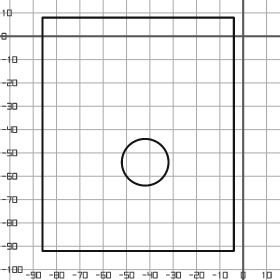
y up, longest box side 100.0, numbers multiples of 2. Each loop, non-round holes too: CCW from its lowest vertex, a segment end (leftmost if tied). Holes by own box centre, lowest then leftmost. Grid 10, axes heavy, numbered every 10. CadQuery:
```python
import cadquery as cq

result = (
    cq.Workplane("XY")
    .moveTo(-86.0, -92.0)
    .lineTo(-4.0, -92.0)
    .lineTo(-4.0, 8.0)
    .lineTo(-86.0, 8.0)
    .close()
    .moveTo(-42.0, -54.0)
    .circle(10.0)
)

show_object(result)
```